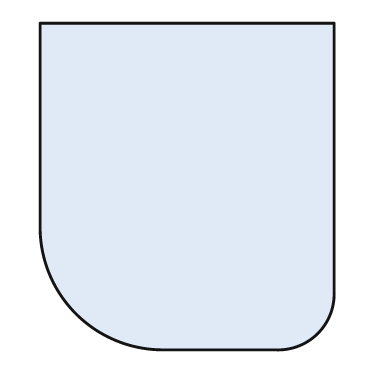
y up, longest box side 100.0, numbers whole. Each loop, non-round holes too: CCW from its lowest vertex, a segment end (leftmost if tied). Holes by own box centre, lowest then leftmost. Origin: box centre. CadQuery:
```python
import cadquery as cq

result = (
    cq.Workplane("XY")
    .moveTo(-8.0, -50.0)
    .lineTo(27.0, -50.0)
    .threePointArc((40.0, -45.0), (45.0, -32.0))
    .lineTo(45.0, 50.0)
    .lineTo(-45.0, 50.0)
    .lineTo(-45.0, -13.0)
    .threePointArc((-34.0, -39.0), (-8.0, -50.0))
    .close()
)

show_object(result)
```